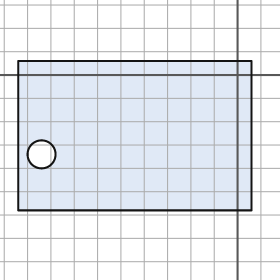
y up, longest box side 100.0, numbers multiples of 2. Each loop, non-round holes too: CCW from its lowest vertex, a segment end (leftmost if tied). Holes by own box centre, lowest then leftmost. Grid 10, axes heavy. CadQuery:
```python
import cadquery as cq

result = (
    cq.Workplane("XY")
    .moveTo(-94.0, -58.0)
    .lineTo(6.0, -58.0)
    .lineTo(6.0, 6.0)
    .lineTo(-94.0, 6.0)
    .close()
    .moveTo(-84.0, -34.0)
    .circle(6.0)
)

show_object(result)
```